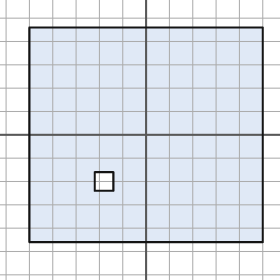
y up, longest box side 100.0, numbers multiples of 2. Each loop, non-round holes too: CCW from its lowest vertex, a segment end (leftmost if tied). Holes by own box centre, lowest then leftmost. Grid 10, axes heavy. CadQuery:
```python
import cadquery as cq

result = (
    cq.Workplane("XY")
    .moveTo(-50.0, -46.0)
    .lineTo(50.0, -46.0)
    .lineTo(50.0, 46.0)
    .lineTo(-50.0, 46.0)
    .close()
    .moveTo(-22.0, -24.0)
    .lineTo(-14.0, -24.0)
    .lineTo(-14.0, -16.0)
    .lineTo(-22.0, -16.0)
    .close()
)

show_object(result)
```